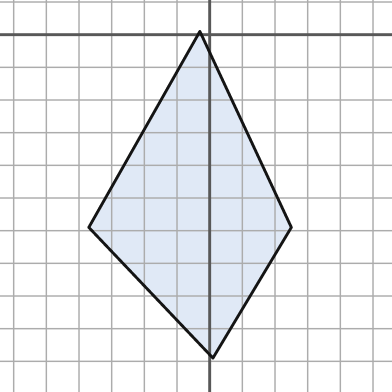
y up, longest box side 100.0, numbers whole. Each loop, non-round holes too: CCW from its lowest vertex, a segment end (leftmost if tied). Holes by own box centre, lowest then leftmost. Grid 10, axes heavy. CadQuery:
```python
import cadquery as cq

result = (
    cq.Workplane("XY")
    .moveTo(1.0, -99.0)
    .lineTo(25.0, -59.0)
    .lineTo(-3.0, 1.0)
    .lineTo(-37.0, -59.0)
    .close()
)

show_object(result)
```